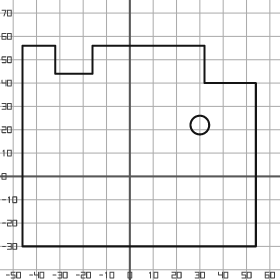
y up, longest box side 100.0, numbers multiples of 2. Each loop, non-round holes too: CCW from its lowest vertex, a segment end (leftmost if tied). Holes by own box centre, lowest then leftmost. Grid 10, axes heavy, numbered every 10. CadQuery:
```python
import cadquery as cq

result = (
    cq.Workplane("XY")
    .moveTo(-46.0, -30.0)
    .lineTo(54.0, -30.0)
    .lineTo(54.0, 40.0)
    .lineTo(32.0, 40.0)
    .lineTo(32.0, 56.0)
    .lineTo(-16.0, 56.0)
    .lineTo(-16.0, 44.0)
    .lineTo(-32.0, 44.0)
    .lineTo(-32.0, 56.0)
    .lineTo(-46.0, 56.0)
    .close()
    .moveTo(30.0, 22.0)
    .circle(4.0)
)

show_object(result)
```